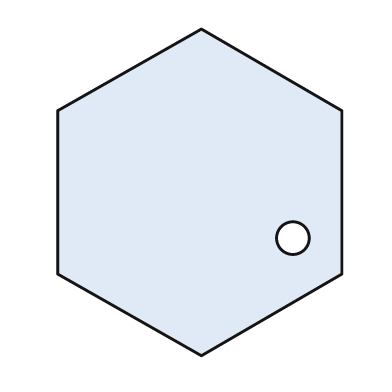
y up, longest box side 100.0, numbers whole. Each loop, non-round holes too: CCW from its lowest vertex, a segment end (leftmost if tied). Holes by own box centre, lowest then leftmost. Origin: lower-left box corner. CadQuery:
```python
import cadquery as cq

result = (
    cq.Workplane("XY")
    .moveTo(44.0, 0.0)
    .lineTo(87.0, 25.0)
    .lineTo(87.0, 75.0)
    .lineTo(44.0, 100.0)
    .lineTo(0.0, 75.0)
    .lineTo(0.0, 25.0)
    .close()
    .moveTo(72.0, 36.0)
    .circle(5.0)
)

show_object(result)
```